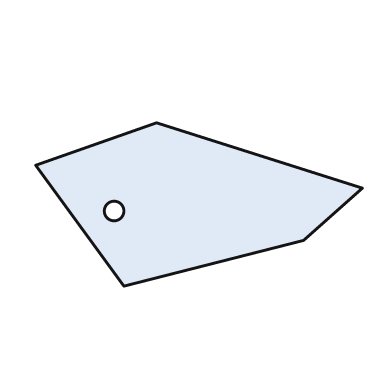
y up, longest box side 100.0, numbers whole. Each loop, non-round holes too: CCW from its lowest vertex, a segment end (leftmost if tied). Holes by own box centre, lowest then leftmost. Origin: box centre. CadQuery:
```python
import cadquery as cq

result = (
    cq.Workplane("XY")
    .moveTo(-23.0, -25.0)
    .lineTo(32.0, -11.0)
    .lineTo(50.0, 5.0)
    .lineTo(-13.0, 25.0)
    .lineTo(-50.0, 12.0)
    .close()
    .moveTo(-26.0, -2.0)
    .circle(3.0)
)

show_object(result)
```